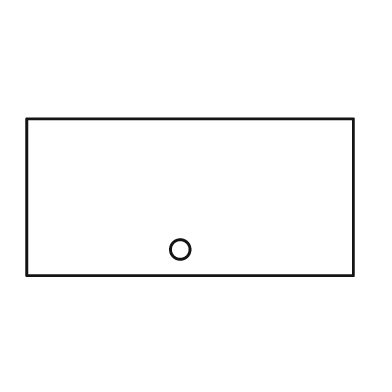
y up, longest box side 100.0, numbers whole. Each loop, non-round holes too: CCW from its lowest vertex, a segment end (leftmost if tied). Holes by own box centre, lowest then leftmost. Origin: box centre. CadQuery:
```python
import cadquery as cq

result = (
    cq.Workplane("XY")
    .moveTo(-50.0, -24.0)
    .lineTo(50.0, -24.0)
    .lineTo(50.0, 24.0)
    .lineTo(-50.0, 24.0)
    .close()
    .moveTo(-3.0, -16.0)
    .circle(3.0)
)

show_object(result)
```